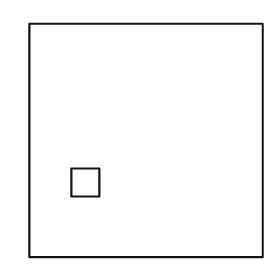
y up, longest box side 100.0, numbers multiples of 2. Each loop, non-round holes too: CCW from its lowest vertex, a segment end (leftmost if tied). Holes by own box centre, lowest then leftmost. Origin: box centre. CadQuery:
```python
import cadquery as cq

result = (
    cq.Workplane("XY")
    .moveTo(-50.0, -50.0)
    .lineTo(50.0, -50.0)
    .lineTo(50.0, 50.0)
    .lineTo(-50.0, 50.0)
    .close()
    .moveTo(-32.0, -24.0)
    .lineTo(-20.0, -24.0)
    .lineTo(-20.0, -12.0)
    .lineTo(-32.0, -12.0)
    .close()
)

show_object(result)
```